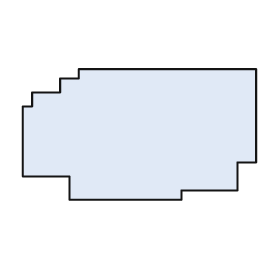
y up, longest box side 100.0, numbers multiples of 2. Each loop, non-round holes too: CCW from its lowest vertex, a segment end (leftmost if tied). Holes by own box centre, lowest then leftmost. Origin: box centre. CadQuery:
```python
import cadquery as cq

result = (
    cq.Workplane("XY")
    .moveTo(-30.0, -28.0)
    .lineTo(18.0, -28.0)
    .lineTo(18.0, -24.0)
    .lineTo(42.0, -24.0)
    .lineTo(42.0, -12.0)
    .lineTo(50.0, -12.0)
    .lineTo(50.0, 28.0)
    .lineTo(-26.0, 28.0)
    .lineTo(-26.0, 24.0)
    .lineTo(-34.0, 24.0)
    .lineTo(-34.0, 18.0)
    .lineTo(-46.0, 18.0)
    .lineTo(-46.0, 12.0)
    .lineTo(-50.0, 12.0)
    .lineTo(-50.0, -18.0)
    .lineTo(-30.0, -18.0)
    .close()
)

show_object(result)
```